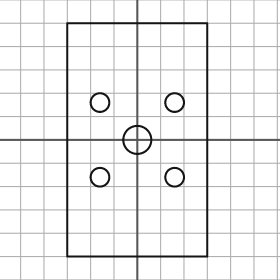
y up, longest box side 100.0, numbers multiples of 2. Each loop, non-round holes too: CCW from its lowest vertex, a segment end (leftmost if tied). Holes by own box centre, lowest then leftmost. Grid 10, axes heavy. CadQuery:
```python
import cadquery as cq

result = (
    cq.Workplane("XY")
    .moveTo(-30.0, -50.0)
    .lineTo(30.0, -50.0)
    .lineTo(30.0, 50.0)
    .lineTo(-30.0, 50.0)
    .close()
    .moveTo(-16.0, -16.0)
    .circle(4.0)
    .moveTo(16.0, -16.0)
    .circle(4.0)
    .moveTo(0.0, 0.0)
    .circle(6.0)
    .moveTo(-16.0, 16.0)
    .circle(4.0)
    .moveTo(16.0, 16.0)
    .circle(4.0)
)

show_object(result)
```